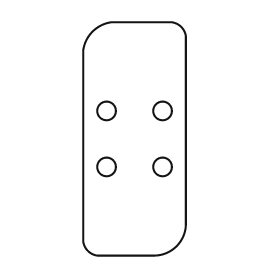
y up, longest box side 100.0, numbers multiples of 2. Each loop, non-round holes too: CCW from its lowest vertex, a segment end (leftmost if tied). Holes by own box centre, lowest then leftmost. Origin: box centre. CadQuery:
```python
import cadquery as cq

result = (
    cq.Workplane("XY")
    .moveTo(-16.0, -50.0)
    .lineTo(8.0, -50.0)
    .threePointArc((18.0, -46.0), (22.0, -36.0))
    .lineTo(22.0, 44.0)
    .threePointArc((20.0, 48.0), (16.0, 50.0))
    .lineTo(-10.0, 50.0)
    .threePointArc((-18.0, 46.0), (-22.0, 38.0))
    .lineTo(-22.0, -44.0)
    .threePointArc((-20.0, -48.0), (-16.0, -50.0))
    .close()
    .moveTo(-12.0, -12.0)
    .circle(4.0)
    .moveTo(12.0, -12.0)
    .circle(4.0)
    .moveTo(-12.0, 12.0)
    .circle(4.0)
    .moveTo(12.0, 12.0)
    .circle(4.0)
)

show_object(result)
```